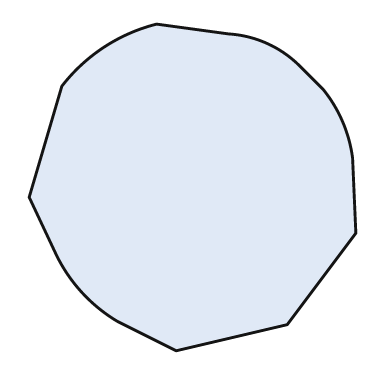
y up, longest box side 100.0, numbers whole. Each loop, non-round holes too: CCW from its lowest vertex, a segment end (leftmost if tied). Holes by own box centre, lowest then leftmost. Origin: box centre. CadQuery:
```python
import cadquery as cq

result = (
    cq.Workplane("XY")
    .moveTo(-5.0, -50.0)
    .lineTo(29.0, -42.0)
    .lineTo(50.0, -14.0)
    .lineTo(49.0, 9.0)
    .threePointArc((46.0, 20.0), (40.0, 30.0))
    .lineTo(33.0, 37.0)
    .threePointArc((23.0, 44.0), (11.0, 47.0))
    .lineTo(-11.0, 50.0)
    .threePointArc((-27.0, 43.0), (-40.0, 31.0))
    .lineTo(-50.0, -3.0)
    .lineTo(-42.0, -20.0)
    .threePointArc((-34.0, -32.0), (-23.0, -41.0))
    .close()
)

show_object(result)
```